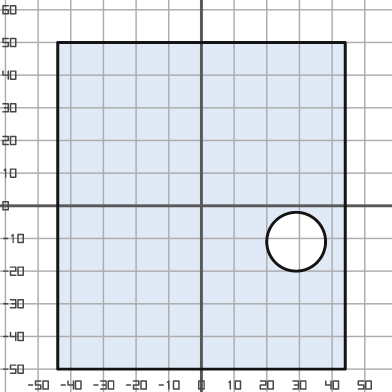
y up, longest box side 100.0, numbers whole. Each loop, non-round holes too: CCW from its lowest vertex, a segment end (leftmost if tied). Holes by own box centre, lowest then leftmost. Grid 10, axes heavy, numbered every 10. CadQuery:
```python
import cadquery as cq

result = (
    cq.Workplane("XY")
    .moveTo(-44.0, -50.0)
    .lineTo(44.0, -50.0)
    .lineTo(44.0, 50.0)
    .lineTo(-44.0, 50.0)
    .close()
    .moveTo(29.0, -11.0)
    .circle(9.0)
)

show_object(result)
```